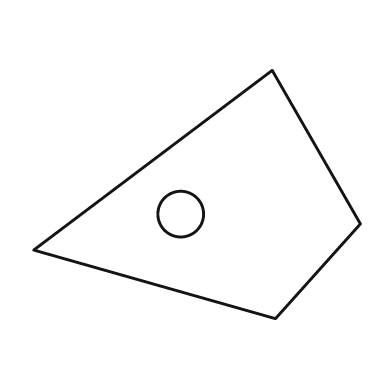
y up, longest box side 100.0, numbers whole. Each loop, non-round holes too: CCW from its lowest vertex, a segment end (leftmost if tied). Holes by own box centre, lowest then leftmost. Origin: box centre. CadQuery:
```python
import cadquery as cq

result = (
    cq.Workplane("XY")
    .moveTo(24.0, -38.0)
    .lineTo(50.0, -9.0)
    .lineTo(23.0, 38.0)
    .lineTo(-50.0, -17.0)
    .close()
    .moveTo(-5.0, -6.0)
    .circle(7.0)
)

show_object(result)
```